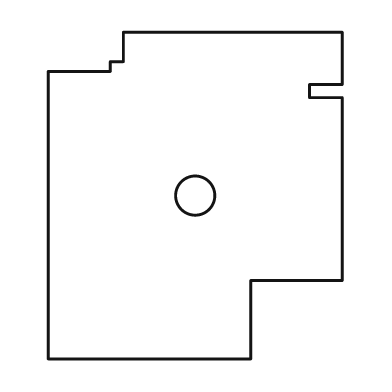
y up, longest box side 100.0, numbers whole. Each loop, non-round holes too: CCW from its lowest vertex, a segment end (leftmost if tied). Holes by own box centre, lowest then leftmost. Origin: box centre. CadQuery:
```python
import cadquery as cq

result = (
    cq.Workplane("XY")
    .moveTo(-45.0, -50.0)
    .lineTo(17.0, -50.0)
    .lineTo(17.0, -26.0)
    .lineTo(45.0, -26.0)
    .lineTo(45.0, 30.0)
    .lineTo(35.0, 30.0)
    .lineTo(35.0, 34.0)
    .lineTo(45.0, 34.0)
    .lineTo(45.0, 50.0)
    .lineTo(-22.0, 50.0)
    .lineTo(-22.0, 41.0)
    .lineTo(-26.0, 41.0)
    .lineTo(-26.0, 38.0)
    .lineTo(-45.0, 38.0)
    .close()
    .moveTo(0.0, 0.0)
    .circle(6.0)
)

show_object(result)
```